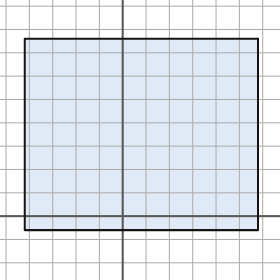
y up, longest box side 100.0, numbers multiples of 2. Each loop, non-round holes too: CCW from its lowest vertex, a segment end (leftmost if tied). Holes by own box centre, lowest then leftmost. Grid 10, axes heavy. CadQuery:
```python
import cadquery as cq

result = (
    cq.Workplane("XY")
    .moveTo(-42.0, -6.0)
    .lineTo(58.0, -6.0)
    .lineTo(58.0, 76.0)
    .lineTo(-42.0, 76.0)
    .close()
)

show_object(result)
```